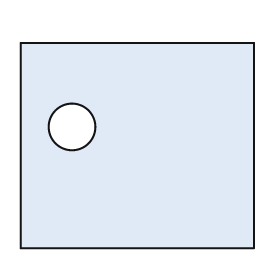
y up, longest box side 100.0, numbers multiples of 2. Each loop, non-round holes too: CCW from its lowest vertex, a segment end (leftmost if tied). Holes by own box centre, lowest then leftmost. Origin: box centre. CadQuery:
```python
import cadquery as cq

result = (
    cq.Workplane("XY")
    .moveTo(-50.0, -44.0)
    .lineTo(50.0, -44.0)
    .lineTo(50.0, 44.0)
    .lineTo(-50.0, 44.0)
    .close()
    .moveTo(-28.0, 8.0)
    .circle(10.0)
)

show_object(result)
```